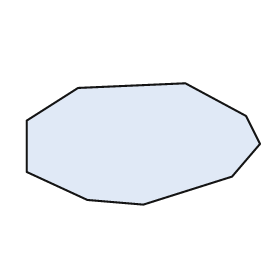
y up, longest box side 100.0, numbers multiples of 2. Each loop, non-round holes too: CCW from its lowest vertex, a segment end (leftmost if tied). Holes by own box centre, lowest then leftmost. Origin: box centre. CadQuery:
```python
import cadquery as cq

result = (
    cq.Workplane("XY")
    .moveTo(0.0, -26.0)
    .lineTo(38.0, -14.0)
    .lineTo(50.0, 0.0)
    .lineTo(44.0, 12.0)
    .lineTo(18.0, 26.0)
    .lineTo(-28.0, 24.0)
    .lineTo(-50.0, 10.0)
    .lineTo(-50.0, -12.0)
    .lineTo(-24.0, -24.0)
    .close()
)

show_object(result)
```